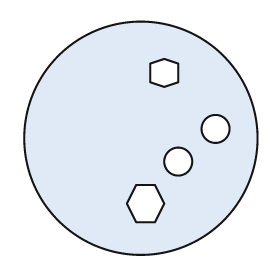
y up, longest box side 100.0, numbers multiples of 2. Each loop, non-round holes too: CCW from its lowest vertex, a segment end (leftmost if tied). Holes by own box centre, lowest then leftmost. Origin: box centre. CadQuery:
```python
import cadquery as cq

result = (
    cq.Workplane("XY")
    .moveTo(0.0, 0.0)
    .circle(50.0)
    .moveTo(-2.0, -36.0)
    .lineTo(6.0, -36.0)
    .lineTo(10.0, -28.0)
    .lineTo(6.0, -20.0)
    .lineTo(-2.0, -20.0)
    .lineTo(-6.0, -28.0)
    .close()
    .moveTo(16.0, -10.0)
    .circle(6.0)
    .moveTo(32.0, 4.0)
    .circle(6.0)
    .moveTo(10.0, 22.0)
    .lineTo(16.0, 24.0)
    .lineTo(16.0, 32.0)
    .lineTo(10.0, 34.0)
    .lineTo(4.0, 32.0)
    .lineTo(4.0, 24.0)
    .close()
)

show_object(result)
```